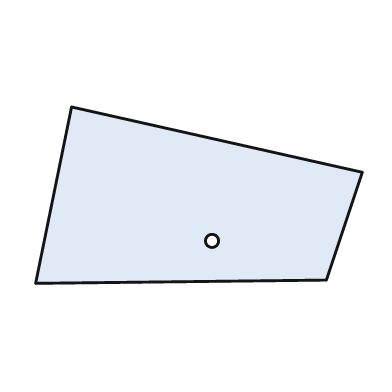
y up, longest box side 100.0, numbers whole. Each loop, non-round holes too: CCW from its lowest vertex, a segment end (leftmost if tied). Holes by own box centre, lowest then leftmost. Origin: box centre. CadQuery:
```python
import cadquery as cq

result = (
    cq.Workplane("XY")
    .moveTo(-50.0, -27.0)
    .lineTo(39.0, -26.0)
    .lineTo(50.0, 7.0)
    .lineTo(-39.0, 27.0)
    .close()
    .moveTo(4.0, -14.0)
    .circle(2.0)
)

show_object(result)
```